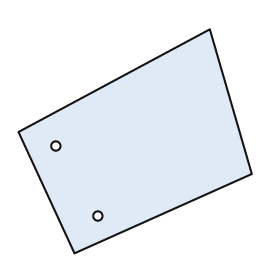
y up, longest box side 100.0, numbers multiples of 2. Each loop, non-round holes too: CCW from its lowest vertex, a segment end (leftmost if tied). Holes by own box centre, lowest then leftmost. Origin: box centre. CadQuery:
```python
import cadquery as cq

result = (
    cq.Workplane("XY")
    .moveTo(-26.0, -48.0)
    .lineTo(50.0, -14.0)
    .lineTo(32.0, 48.0)
    .lineTo(-50.0, 4.0)
    .close()
    .moveTo(-16.0, -32.0)
    .circle(2.0)
    .moveTo(-34.0, -2.0)
    .circle(2.0)
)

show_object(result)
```